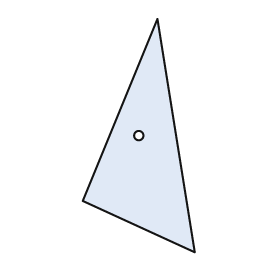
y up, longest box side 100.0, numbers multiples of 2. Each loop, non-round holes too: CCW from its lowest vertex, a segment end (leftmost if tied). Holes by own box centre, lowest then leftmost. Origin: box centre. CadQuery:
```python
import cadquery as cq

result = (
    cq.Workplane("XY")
    .moveTo(24.0, -50.0)
    .lineTo(8.0, 50.0)
    .lineTo(-24.0, -28.0)
    .close()
    .moveTo(0.0, 0.0)
    .circle(2.0)
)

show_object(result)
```